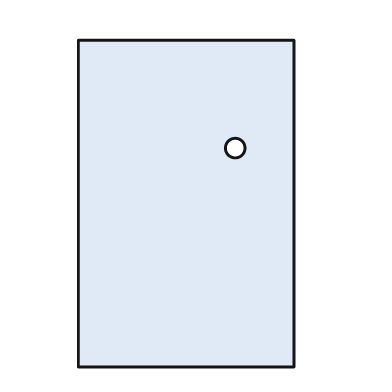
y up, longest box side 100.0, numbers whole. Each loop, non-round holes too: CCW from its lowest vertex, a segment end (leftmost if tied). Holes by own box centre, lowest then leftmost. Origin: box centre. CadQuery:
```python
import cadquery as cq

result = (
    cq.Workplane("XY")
    .moveTo(-33.0, -50.0)
    .lineTo(33.0, -50.0)
    .lineTo(33.0, 50.0)
    .lineTo(-33.0, 50.0)
    .close()
    .moveTo(15.0, 17.0)
    .circle(3.0)
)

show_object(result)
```